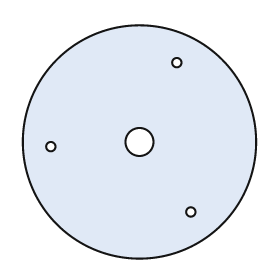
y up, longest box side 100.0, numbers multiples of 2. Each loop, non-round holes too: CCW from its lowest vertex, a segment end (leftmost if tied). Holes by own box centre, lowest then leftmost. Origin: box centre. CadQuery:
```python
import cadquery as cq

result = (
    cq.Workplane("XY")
    .moveTo(0.0, 0.0)
    .circle(50.0)
    .moveTo(22.0, -30.0)
    .circle(2.0)
    .moveTo(-38.0, -2.0)
    .circle(2.0)
    .moveTo(0.0, 0.0)
    .circle(6.0)
    .moveTo(16.0, 34.0)
    .circle(2.0)
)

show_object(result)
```